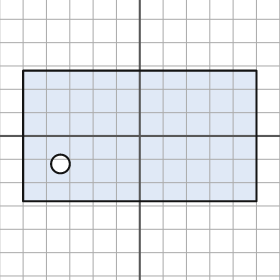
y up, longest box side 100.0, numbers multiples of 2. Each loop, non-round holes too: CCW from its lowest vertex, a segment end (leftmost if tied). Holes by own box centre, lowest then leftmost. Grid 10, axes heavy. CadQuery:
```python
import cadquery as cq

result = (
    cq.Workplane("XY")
    .moveTo(-50.0, -28.0)
    .lineTo(50.0, -28.0)
    .lineTo(50.0, 28.0)
    .lineTo(-50.0, 28.0)
    .close()
    .moveTo(-34.0, -12.0)
    .circle(4.0)
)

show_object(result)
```